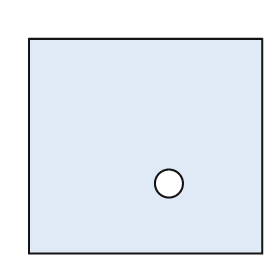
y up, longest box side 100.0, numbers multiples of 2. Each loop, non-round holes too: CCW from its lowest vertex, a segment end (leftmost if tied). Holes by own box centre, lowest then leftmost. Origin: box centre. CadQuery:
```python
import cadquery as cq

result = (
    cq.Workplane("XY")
    .moveTo(-50.0, -46.0)
    .lineTo(50.0, -46.0)
    .lineTo(50.0, 46.0)
    .lineTo(-50.0, 46.0)
    .close()
    .moveTo(10.0, -16.0)
    .circle(6.0)
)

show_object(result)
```